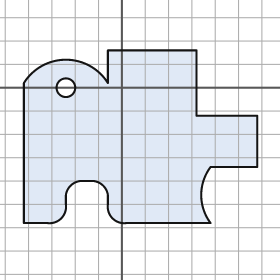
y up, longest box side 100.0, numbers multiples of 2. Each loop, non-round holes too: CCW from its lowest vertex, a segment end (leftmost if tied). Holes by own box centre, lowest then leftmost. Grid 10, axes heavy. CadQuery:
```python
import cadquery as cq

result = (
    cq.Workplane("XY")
    .moveTo(-42.0, -58.0)
    .lineTo(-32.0, -58.0)
    .threePointArc((-26.0, -56.0), (-24.0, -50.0))
    .lineTo(-24.0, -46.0)
    .threePointArc((-22.0, -42.0), (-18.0, -40.0))
    .lineTo(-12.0, -40.0)
    .threePointArc((-8.0, -42.0), (-6.0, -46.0))
    .lineTo(-6.0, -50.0)
    .threePointArc((-4.0, -56.0), (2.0, -58.0))
    .lineTo(38.0, -58.0)
    .threePointArc((34.0, -46.0), (38.0, -34.0))
    .lineTo(58.0, -34.0)
    .lineTo(58.0, -12.0)
    .lineTo(32.0, -12.0)
    .lineTo(32.0, 16.0)
    .lineTo(-6.0, 16.0)
    .lineTo(-6.0, 2.0)
    .threePointArc((-24.0, 12.0), (-42.0, 2.0))
    .close()
    .moveTo(-24.0, 0.0)
    .circle(4.0)
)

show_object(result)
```